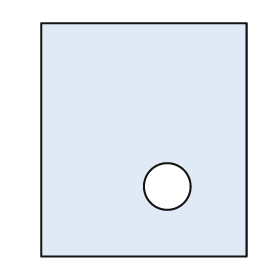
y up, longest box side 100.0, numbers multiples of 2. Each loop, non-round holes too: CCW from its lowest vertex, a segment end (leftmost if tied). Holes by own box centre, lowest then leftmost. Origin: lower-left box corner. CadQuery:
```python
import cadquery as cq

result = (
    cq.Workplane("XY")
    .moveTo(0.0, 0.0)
    .lineTo(88.0, 0.0)
    .lineTo(88.0, 100.0)
    .lineTo(0.0, 100.0)
    .close()
    .moveTo(54.0, 30.0)
    .circle(10.0)
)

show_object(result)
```